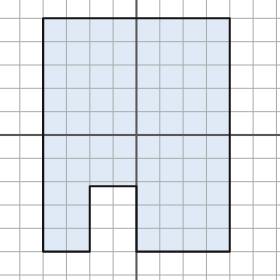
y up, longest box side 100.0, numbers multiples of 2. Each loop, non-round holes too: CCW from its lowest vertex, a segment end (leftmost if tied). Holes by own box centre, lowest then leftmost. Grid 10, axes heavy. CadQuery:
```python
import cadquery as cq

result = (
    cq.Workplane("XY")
    .moveTo(-40.0, -50.0)
    .lineTo(-20.0, -50.0)
    .lineTo(-20.0, -22.0)
    .lineTo(0.0, -22.0)
    .lineTo(0.0, -50.0)
    .lineTo(40.0, -50.0)
    .lineTo(40.0, 50.0)
    .lineTo(-40.0, 50.0)
    .close()
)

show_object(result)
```